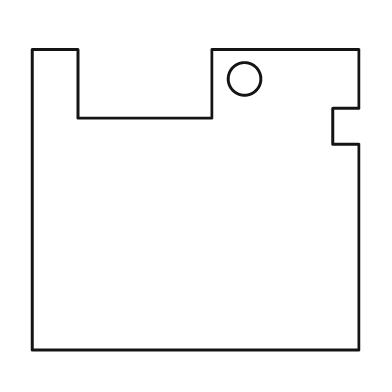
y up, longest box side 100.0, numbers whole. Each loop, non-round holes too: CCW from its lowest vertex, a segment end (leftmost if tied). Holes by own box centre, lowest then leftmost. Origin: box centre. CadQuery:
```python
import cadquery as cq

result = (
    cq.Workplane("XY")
    .moveTo(-50.0, -46.0)
    .lineTo(50.0, -46.0)
    .lineTo(50.0, 17.0)
    .lineTo(42.0, 17.0)
    .lineTo(42.0, 28.0)
    .lineTo(50.0, 28.0)
    .lineTo(50.0, 46.0)
    .lineTo(5.0, 46.0)
    .lineTo(5.0, 25.0)
    .lineTo(-36.0, 25.0)
    .lineTo(-36.0, 46.0)
    .lineTo(-50.0, 46.0)
    .close()
    .moveTo(15.0, 37.0)
    .circle(5.0)
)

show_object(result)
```